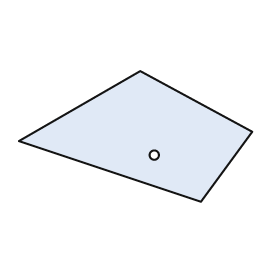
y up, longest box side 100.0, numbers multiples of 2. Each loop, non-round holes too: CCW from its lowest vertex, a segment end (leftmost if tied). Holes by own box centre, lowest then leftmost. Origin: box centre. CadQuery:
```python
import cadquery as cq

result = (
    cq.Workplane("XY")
    .moveTo(28.0, -28.0)
    .lineTo(50.0, 2.0)
    .lineTo(2.0, 28.0)
    .lineTo(-50.0, -2.0)
    .close()
    .moveTo(8.0, -8.0)
    .circle(2.0)
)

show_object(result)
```